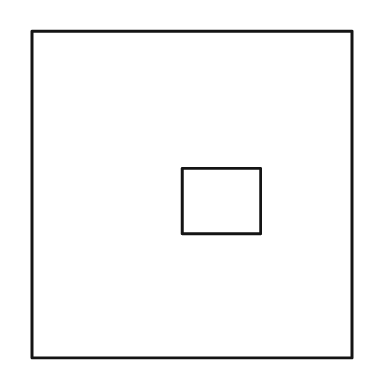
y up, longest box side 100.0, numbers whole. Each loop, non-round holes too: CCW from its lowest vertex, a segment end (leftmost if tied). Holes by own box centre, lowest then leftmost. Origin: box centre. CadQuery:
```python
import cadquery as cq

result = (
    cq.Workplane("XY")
    .moveTo(-49.0, -50.0)
    .lineTo(49.0, -50.0)
    .lineTo(49.0, 50.0)
    .lineTo(-49.0, 50.0)
    .close()
    .moveTo(-3.0, -12.0)
    .lineTo(21.0, -12.0)
    .lineTo(21.0, 8.0)
    .lineTo(-3.0, 8.0)
    .close()
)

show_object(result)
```